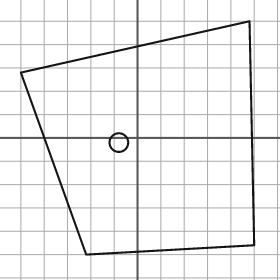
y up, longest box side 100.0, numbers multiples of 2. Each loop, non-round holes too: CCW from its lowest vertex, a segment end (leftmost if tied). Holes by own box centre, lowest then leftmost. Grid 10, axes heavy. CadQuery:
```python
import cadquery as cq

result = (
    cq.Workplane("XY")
    .moveTo(-22.0, -50.0)
    .lineTo(50.0, -46.0)
    .lineTo(48.0, 50.0)
    .lineTo(-50.0, 28.0)
    .close()
    .moveTo(-8.0, -2.0)
    .circle(4.0)
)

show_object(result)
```